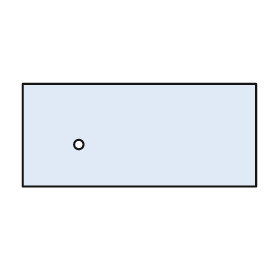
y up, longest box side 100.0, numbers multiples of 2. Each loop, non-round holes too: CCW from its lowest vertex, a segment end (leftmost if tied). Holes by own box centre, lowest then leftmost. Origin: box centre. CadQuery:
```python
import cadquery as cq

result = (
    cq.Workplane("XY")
    .moveTo(-50.0, -22.0)
    .lineTo(50.0, -22.0)
    .lineTo(50.0, 22.0)
    .lineTo(-50.0, 22.0)
    .close()
    .moveTo(-26.0, -4.0)
    .circle(2.0)
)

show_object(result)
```